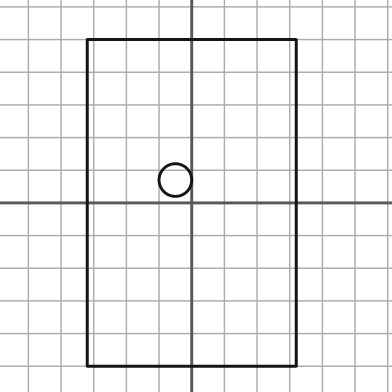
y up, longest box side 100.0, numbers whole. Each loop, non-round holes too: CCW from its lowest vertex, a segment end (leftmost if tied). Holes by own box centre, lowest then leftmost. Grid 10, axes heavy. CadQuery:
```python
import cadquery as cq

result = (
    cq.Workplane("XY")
    .moveTo(-32.0, -50.0)
    .lineTo(32.0, -50.0)
    .lineTo(32.0, 50.0)
    .lineTo(-32.0, 50.0)
    .close()
    .moveTo(-5.0, 7.0)
    .circle(5.0)
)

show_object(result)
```